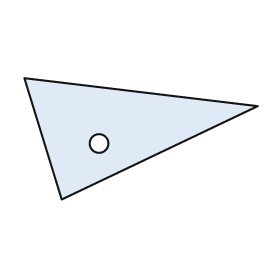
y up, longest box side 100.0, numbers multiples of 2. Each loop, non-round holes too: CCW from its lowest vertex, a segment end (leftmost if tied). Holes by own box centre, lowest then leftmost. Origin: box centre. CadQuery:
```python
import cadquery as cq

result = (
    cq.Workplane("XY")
    .moveTo(-34.0, -26.0)
    .lineTo(50.0, 14.0)
    .lineTo(-50.0, 26.0)
    .close()
    .moveTo(-18.0, -2.0)
    .circle(4.0)
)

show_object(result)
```